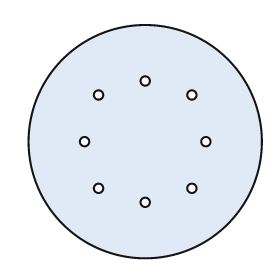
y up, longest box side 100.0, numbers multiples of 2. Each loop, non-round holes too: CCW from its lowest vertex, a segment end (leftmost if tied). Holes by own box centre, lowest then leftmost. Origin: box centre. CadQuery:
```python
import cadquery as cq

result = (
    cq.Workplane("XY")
    .moveTo(0.0, 0.0)
    .circle(50.0)
    .moveTo(0.0, -26.0)
    .circle(2.0)
    .moveTo(-20.0, -20.0)
    .circle(2.0)
    .moveTo(20.0, -20.0)
    .circle(2.0)
    .moveTo(-26.0, 0.0)
    .circle(2.0)
    .moveTo(26.0, 0.0)
    .circle(2.0)
    .moveTo(-20.0, 20.0)
    .circle(2.0)
    .moveTo(20.0, 20.0)
    .circle(2.0)
    .moveTo(0.0, 26.0)
    .circle(2.0)
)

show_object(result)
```